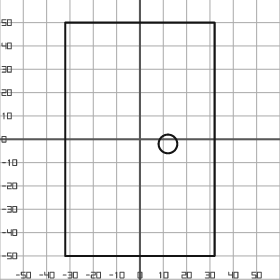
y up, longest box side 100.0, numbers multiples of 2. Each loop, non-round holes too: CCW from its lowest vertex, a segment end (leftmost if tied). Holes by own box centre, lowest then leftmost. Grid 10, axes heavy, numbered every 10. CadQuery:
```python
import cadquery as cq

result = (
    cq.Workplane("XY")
    .moveTo(-32.0, -50.0)
    .lineTo(32.0, -50.0)
    .lineTo(32.0, 50.0)
    .lineTo(-32.0, 50.0)
    .close()
    .moveTo(12.0, -2.0)
    .circle(4.0)
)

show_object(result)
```